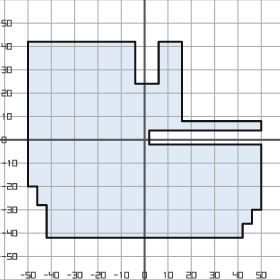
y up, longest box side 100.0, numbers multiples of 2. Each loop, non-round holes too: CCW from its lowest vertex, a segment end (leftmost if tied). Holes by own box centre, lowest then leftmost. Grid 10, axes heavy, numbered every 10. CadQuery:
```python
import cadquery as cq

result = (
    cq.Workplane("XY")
    .moveTo(-42.0, -42.0)
    .lineTo(42.0, -42.0)
    .lineTo(42.0, -36.0)
    .lineTo(46.0, -36.0)
    .lineTo(46.0, -30.0)
    .lineTo(50.0, -30.0)
    .lineTo(50.0, -2.0)
    .lineTo(2.0, -2.0)
    .lineTo(2.0, 4.0)
    .lineTo(50.0, 4.0)
    .lineTo(50.0, 8.0)
    .lineTo(16.0, 8.0)
    .lineTo(16.0, 42.0)
    .lineTo(6.0, 42.0)
    .lineTo(6.0, 24.0)
    .lineTo(-4.0, 24.0)
    .lineTo(-4.0, 42.0)
    .lineTo(-50.0, 42.0)
    .lineTo(-50.0, -20.0)
    .lineTo(-46.0, -20.0)
    .lineTo(-46.0, -28.0)
    .lineTo(-42.0, -28.0)
    .close()
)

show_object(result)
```